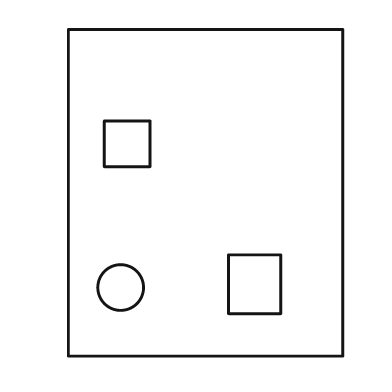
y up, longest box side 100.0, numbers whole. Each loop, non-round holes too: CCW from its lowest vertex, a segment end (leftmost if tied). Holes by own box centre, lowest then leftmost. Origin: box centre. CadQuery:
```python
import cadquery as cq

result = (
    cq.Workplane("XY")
    .moveTo(-42.0, -50.0)
    .lineTo(42.0, -50.0)
    .lineTo(42.0, 50.0)
    .lineTo(-42.0, 50.0)
    .close()
    .moveTo(-26.0, -29.0)
    .circle(7.0)
    .moveTo(7.0, -37.0)
    .lineTo(23.0, -37.0)
    .lineTo(23.0, -19.0)
    .lineTo(7.0, -19.0)
    .close()
    .moveTo(-31.0, 8.0)
    .lineTo(-17.0, 8.0)
    .lineTo(-17.0, 22.0)
    .lineTo(-31.0, 22.0)
    .close()
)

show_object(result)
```